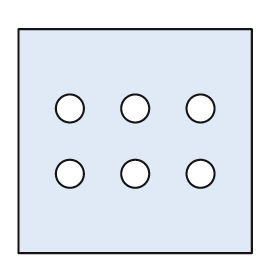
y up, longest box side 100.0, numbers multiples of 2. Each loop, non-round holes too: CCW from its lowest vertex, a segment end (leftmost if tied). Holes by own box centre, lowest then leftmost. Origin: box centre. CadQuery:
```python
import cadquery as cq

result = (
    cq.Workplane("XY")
    .moveTo(-50.0, -48.0)
    .lineTo(50.0, -48.0)
    .lineTo(50.0, 48.0)
    .lineTo(-50.0, 48.0)
    .close()
    .moveTo(-28.0, -14.0)
    .circle(6.0)
    .moveTo(0.0, -14.0)
    .circle(6.0)
    .moveTo(28.0, -14.0)
    .circle(6.0)
    .moveTo(-28.0, 14.0)
    .circle(6.0)
    .moveTo(0.0, 14.0)
    .circle(6.0)
    .moveTo(28.0, 14.0)
    .circle(6.0)
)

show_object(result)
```